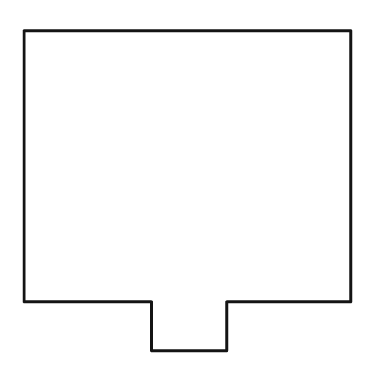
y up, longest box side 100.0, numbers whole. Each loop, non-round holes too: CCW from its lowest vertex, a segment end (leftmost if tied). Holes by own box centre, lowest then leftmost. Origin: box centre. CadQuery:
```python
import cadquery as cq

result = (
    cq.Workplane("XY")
    .moveTo(-11.0, -49.0)
    .lineTo(12.0, -49.0)
    .lineTo(12.0, -34.0)
    .lineTo(50.0, -34.0)
    .lineTo(50.0, 49.0)
    .lineTo(-50.0, 49.0)
    .lineTo(-50.0, -34.0)
    .lineTo(-11.0, -34.0)
    .close()
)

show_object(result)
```